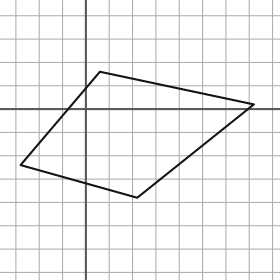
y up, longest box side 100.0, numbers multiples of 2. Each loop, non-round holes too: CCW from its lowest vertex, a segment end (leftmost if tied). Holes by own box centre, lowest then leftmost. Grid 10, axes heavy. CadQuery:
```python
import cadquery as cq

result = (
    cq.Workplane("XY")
    .moveTo(22.0, -38.0)
    .lineTo(72.0, 2.0)
    .lineTo(6.0, 16.0)
    .lineTo(-28.0, -24.0)
    .close()
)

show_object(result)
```